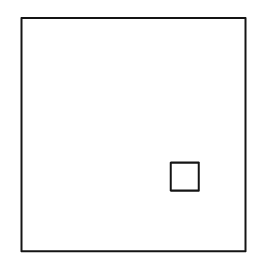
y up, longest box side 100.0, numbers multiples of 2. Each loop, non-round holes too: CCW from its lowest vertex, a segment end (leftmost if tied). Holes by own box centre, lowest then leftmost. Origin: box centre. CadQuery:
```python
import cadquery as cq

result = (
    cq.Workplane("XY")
    .moveTo(-48.0, -50.0)
    .lineTo(48.0, -50.0)
    .lineTo(48.0, 50.0)
    .lineTo(-48.0, 50.0)
    .close()
    .moveTo(16.0, -24.0)
    .lineTo(28.0, -24.0)
    .lineTo(28.0, -12.0)
    .lineTo(16.0, -12.0)
    .close()
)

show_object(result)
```